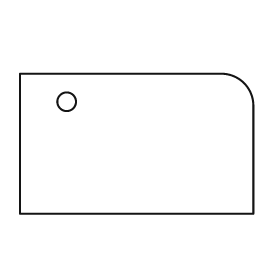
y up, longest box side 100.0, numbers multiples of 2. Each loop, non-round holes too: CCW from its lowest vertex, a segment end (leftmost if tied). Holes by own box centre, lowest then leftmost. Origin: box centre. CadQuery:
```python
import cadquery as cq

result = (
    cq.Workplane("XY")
    .moveTo(-50.0, -30.0)
    .lineTo(50.0, -30.0)
    .lineTo(50.0, 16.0)
    .threePointArc((46.0, 26.0), (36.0, 30.0))
    .lineTo(-50.0, 30.0)
    .close()
    .moveTo(-30.0, 18.0)
    .circle(4.0)
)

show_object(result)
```